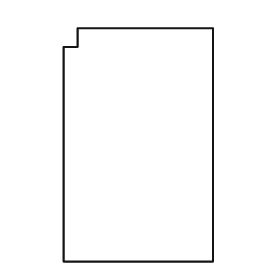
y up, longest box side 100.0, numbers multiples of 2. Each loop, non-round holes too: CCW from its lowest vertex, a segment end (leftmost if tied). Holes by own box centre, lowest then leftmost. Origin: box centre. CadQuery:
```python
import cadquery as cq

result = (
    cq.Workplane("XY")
    .moveTo(-32.0, -50.0)
    .lineTo(32.0, -50.0)
    .lineTo(32.0, 50.0)
    .lineTo(-26.0, 50.0)
    .lineTo(-26.0, 42.0)
    .lineTo(-32.0, 42.0)
    .close()
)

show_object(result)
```